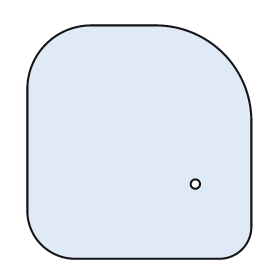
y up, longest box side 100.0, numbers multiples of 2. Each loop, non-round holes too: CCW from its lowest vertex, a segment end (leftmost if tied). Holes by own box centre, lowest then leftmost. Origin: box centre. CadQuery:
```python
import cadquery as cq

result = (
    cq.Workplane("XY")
    .moveTo(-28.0, -50.0)
    .lineTo(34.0, -50.0)
    .threePointArc((44.0, -46.0), (48.0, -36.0))
    .lineTo(48.0, 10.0)
    .threePointArc((36.0, 38.0), (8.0, 50.0))
    .lineTo(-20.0, 50.0)
    .threePointArc((-40.0, 42.0), (-48.0, 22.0))
    .lineTo(-48.0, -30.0)
    .threePointArc((-42.0, -44.0), (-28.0, -50.0))
    .close()
    .moveTo(24.0, -18.0)
    .circle(2.0)
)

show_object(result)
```